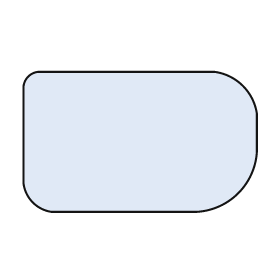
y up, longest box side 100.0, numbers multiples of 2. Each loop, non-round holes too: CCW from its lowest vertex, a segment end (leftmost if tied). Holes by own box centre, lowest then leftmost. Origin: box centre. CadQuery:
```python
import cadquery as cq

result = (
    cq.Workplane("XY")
    .moveTo(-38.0, -30.0)
    .lineTo(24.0, -30.0)
    .threePointArc((42.0, -22.0), (50.0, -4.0))
    .lineTo(50.0, 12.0)
    .threePointArc((44.0, 24.0), (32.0, 30.0))
    .lineTo(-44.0, 30.0)
    .threePointArc((-48.0, 28.0), (-50.0, 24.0))
    .lineTo(-50.0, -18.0)
    .threePointArc((-46.0, -26.0), (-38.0, -30.0))
    .close()
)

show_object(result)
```